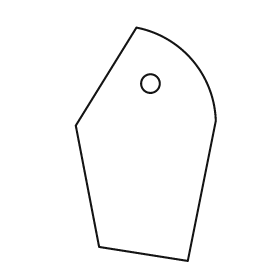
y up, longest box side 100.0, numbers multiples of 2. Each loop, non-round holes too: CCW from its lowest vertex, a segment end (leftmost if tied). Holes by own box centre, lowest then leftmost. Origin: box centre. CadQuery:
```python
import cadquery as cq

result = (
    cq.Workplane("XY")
    .moveTo(18.0, -50.0)
    .lineTo(30.0, 10.0)
    .threePointArc((20.0, 36.0), (-4.0, 50.0))
    .lineTo(-30.0, 8.0)
    .lineTo(-20.0, -44.0)
    .close()
    .moveTo(2.0, 26.0)
    .circle(4.0)
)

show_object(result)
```